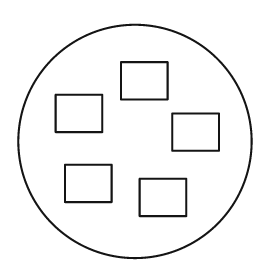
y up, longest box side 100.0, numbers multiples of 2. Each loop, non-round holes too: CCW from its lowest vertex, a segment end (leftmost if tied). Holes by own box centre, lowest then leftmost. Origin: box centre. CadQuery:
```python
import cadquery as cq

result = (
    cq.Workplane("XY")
    .moveTo(0.0, 0.0)
    .circle(50.0)
    .moveTo(2.0, -32.0)
    .lineTo(22.0, -32.0)
    .lineTo(22.0, -16.0)
    .lineTo(2.0, -16.0)
    .close()
    .moveTo(-30.0, -26.0)
    .lineTo(-10.0, -26.0)
    .lineTo(-10.0, -10.0)
    .lineTo(-30.0, -10.0)
    .close()
    .moveTo(16.0, -4.0)
    .lineTo(36.0, -4.0)
    .lineTo(36.0, 12.0)
    .lineTo(16.0, 12.0)
    .close()
    .moveTo(-34.0, 4.0)
    .lineTo(-14.0, 4.0)
    .lineTo(-14.0, 20.0)
    .lineTo(-34.0, 20.0)
    .close()
    .moveTo(-6.0, 18.0)
    .lineTo(14.0, 18.0)
    .lineTo(14.0, 34.0)
    .lineTo(-6.0, 34.0)
    .close()
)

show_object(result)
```